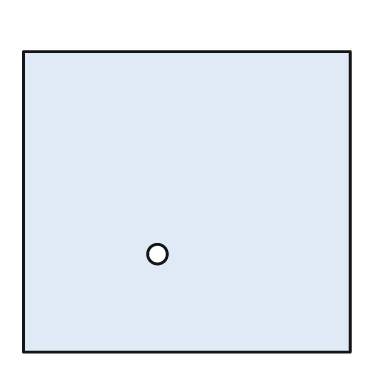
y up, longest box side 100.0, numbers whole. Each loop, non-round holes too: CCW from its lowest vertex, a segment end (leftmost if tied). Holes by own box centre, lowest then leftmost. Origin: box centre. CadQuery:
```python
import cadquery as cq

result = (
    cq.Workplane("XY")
    .moveTo(-50.0, -46.0)
    .lineTo(50.0, -46.0)
    .lineTo(50.0, 46.0)
    .lineTo(-50.0, 46.0)
    .close()
    .moveTo(-9.0, -16.0)
    .circle(3.0)
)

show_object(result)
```